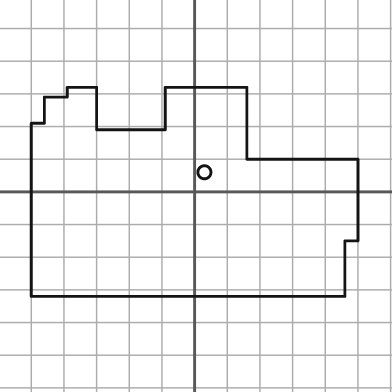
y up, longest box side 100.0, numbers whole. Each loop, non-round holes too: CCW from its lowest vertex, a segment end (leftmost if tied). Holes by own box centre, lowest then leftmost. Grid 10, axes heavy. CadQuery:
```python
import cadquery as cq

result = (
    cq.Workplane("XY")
    .moveTo(-50.0, -32.0)
    .lineTo(46.0, -32.0)
    .lineTo(46.0, -15.0)
    .lineTo(50.0, -15.0)
    .lineTo(50.0, 10.0)
    .lineTo(16.0, 10.0)
    .lineTo(16.0, 32.0)
    .lineTo(-9.0, 32.0)
    .lineTo(-9.0, 19.0)
    .lineTo(-30.0, 19.0)
    .lineTo(-30.0, 32.0)
    .lineTo(-39.0, 32.0)
    .lineTo(-39.0, 29.0)
    .lineTo(-46.0, 29.0)
    .lineTo(-46.0, 21.0)
    .lineTo(-50.0, 21.0)
    .close()
    .moveTo(3.0, 6.0)
    .circle(2.0)
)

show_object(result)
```